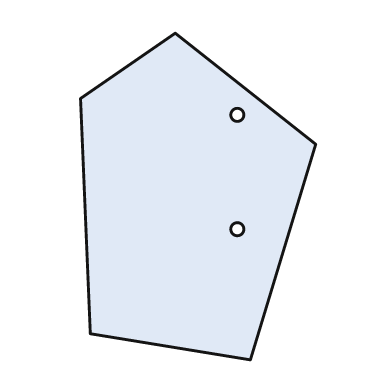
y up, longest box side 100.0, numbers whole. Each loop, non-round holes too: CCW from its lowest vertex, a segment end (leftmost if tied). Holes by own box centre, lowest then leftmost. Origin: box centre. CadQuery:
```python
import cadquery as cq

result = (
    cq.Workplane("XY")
    .moveTo(16.0, -50.0)
    .lineTo(36.0, 16.0)
    .lineTo(-7.0, 50.0)
    .lineTo(-36.0, 30.0)
    .lineTo(-33.0, -42.0)
    .close()
    .moveTo(12.0, -10.0)
    .circle(2.0)
    .moveTo(12.0, 25.0)
    .circle(2.0)
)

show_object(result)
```